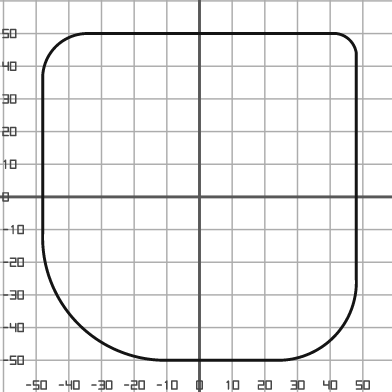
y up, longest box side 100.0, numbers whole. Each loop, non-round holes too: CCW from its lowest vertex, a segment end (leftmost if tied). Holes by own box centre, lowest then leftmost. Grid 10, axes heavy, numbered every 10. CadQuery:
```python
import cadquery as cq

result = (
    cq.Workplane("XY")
    .moveTo(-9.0, -50.0)
    .lineTo(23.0, -50.0)
    .threePointArc((41.0, -43.0), (48.0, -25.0))
    .lineTo(48.0, 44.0)
    .threePointArc((46.0, 48.0), (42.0, 50.0))
    .lineTo(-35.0, 50.0)
    .threePointArc((-44.0, 46.0), (-48.0, 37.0))
    .lineTo(-48.0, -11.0)
    .threePointArc((-37.0, -39.0), (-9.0, -50.0))
    .close()
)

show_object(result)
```